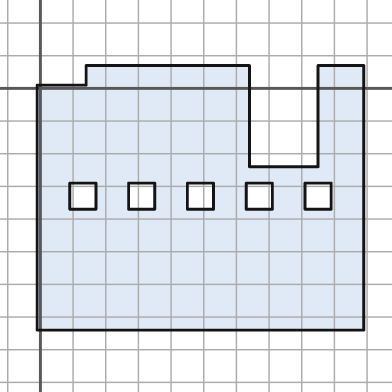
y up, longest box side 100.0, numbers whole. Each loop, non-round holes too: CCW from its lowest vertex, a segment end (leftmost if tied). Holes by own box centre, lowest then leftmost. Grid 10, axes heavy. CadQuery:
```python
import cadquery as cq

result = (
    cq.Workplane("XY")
    .moveTo(-1.0, -74.0)
    .lineTo(99.0, -74.0)
    .lineTo(99.0, 7.0)
    .lineTo(85.0, 7.0)
    .lineTo(85.0, -24.0)
    .lineTo(64.0, -24.0)
    .lineTo(64.0, 7.0)
    .lineTo(14.0, 7.0)
    .lineTo(14.0, 1.0)
    .lineTo(-1.0, 1.0)
    .close()
    .moveTo(9.0, -37.0)
    .lineTo(17.0, -37.0)
    .lineTo(17.0, -29.0)
    .lineTo(9.0, -29.0)
    .close()
    .moveTo(27.0, -37.0)
    .lineTo(35.0, -37.0)
    .lineTo(35.0, -29.0)
    .lineTo(27.0, -29.0)
    .close()
    .moveTo(45.0, -37.0)
    .lineTo(53.0, -37.0)
    .lineTo(53.0, -29.0)
    .lineTo(45.0, -29.0)
    .close()
    .moveTo(63.0, -37.0)
    .lineTo(71.0, -37.0)
    .lineTo(71.0, -29.0)
    .lineTo(63.0, -29.0)
    .close()
    .moveTo(81.0, -37.0)
    .lineTo(89.0, -37.0)
    .lineTo(89.0, -29.0)
    .lineTo(81.0, -29.0)
    .close()
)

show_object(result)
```